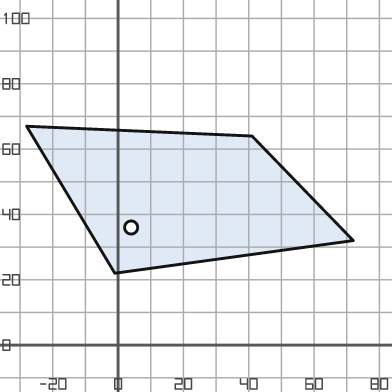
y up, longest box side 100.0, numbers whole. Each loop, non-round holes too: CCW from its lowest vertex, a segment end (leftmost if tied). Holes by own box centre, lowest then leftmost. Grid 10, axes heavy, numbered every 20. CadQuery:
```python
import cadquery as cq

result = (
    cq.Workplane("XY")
    .moveTo(-1.0, 22.0)
    .lineTo(72.0, 32.0)
    .lineTo(41.0, 64.0)
    .lineTo(-28.0, 67.0)
    .close()
    .moveTo(4.0, 36.0)
    .circle(2.0)
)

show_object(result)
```